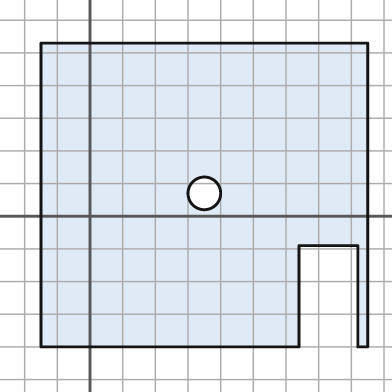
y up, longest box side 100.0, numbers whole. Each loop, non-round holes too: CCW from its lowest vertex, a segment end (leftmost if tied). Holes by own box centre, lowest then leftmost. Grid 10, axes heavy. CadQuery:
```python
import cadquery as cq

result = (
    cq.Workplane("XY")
    .moveTo(-15.0, -40.0)
    .lineTo(64.0, -40.0)
    .lineTo(64.0, -9.0)
    .lineTo(82.0, -9.0)
    .lineTo(82.0, -40.0)
    .lineTo(85.0, -40.0)
    .lineTo(85.0, 53.0)
    .lineTo(-15.0, 53.0)
    .close()
    .moveTo(35.0, 7.0)
    .circle(5.0)
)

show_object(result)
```